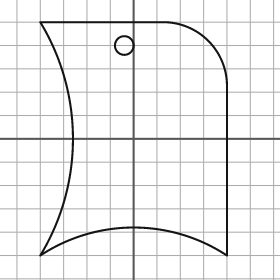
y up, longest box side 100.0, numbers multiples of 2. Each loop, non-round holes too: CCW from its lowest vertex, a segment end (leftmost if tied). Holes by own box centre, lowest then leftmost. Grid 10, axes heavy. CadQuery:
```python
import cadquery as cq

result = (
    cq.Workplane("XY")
    .moveTo(-40.0, -50.0)
    .threePointArc((0.0, -38.0), (40.0, -50.0))
    .lineTo(40.0, 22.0)
    .threePointArc((32.0, 42.0), (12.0, 50.0))
    .lineTo(-40.0, 50.0)
    .threePointArc((-26.0, 0.0), (-40.0, -50.0))
    .close()
    .moveTo(-4.0, 40.0)
    .circle(4.0)
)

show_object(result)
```